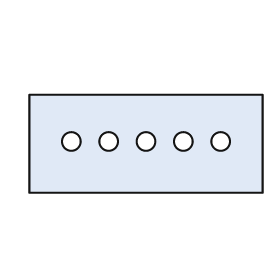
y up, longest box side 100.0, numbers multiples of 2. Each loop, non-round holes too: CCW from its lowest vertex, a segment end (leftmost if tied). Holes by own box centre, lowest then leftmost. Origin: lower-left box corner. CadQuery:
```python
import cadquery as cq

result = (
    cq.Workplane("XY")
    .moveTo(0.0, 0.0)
    .lineTo(100.0, 0.0)
    .lineTo(100.0, 42.0)
    .lineTo(0.0, 42.0)
    .close()
    .moveTo(18.0, 22.0)
    .circle(4.0)
    .moveTo(34.0, 22.0)
    .circle(4.0)
    .moveTo(50.0, 22.0)
    .circle(4.0)
    .moveTo(66.0, 22.0)
    .circle(4.0)
    .moveTo(82.0, 22.0)
    .circle(4.0)
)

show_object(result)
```